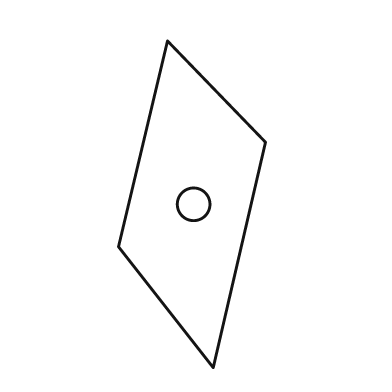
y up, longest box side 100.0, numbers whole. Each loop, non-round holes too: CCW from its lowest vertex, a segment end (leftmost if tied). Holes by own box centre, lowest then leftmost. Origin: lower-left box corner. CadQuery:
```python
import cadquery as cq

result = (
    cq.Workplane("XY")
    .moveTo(29.0, 0.0)
    .lineTo(45.0, 69.0)
    .lineTo(15.0, 100.0)
    .lineTo(0.0, 37.0)
    .close()
    .moveTo(23.0, 50.0)
    .circle(5.0)
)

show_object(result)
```